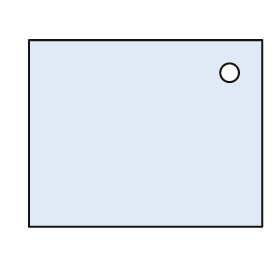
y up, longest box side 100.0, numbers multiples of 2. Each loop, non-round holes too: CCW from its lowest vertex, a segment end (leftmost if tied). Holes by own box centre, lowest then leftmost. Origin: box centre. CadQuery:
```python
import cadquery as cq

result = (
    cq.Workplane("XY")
    .moveTo(-50.0, -40.0)
    .lineTo(50.0, -40.0)
    .lineTo(50.0, 40.0)
    .lineTo(-50.0, 40.0)
    .close()
    .moveTo(36.0, 26.0)
    .circle(4.0)
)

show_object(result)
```